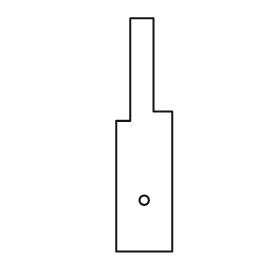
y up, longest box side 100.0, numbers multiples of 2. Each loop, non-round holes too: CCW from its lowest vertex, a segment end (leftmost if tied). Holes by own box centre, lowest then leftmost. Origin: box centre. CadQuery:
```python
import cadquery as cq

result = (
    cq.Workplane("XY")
    .moveTo(-12.0, -50.0)
    .lineTo(12.0, -50.0)
    .lineTo(12.0, 10.0)
    .lineTo(4.0, 10.0)
    .lineTo(4.0, 50.0)
    .lineTo(-6.0, 50.0)
    .lineTo(-6.0, 6.0)
    .lineTo(-12.0, 6.0)
    .close()
    .moveTo(0.0, -28.0)
    .circle(2.0)
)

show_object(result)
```